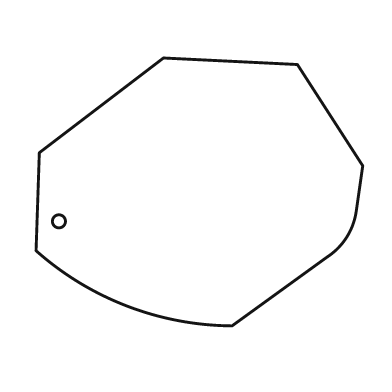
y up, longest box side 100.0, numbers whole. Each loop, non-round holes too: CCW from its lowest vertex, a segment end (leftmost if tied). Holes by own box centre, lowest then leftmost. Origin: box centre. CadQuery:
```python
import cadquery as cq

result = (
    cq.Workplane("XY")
    .moveTo(10.0, -41.0)
    .lineTo(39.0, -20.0)
    .threePointArc((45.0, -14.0), (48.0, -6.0))
    .lineTo(50.0, 8.0)
    .lineTo(30.0, 39.0)
    .lineTo(-11.0, 41.0)
    .lineTo(-49.0, 12.0)
    .lineTo(-50.0, -18.0)
    .threePointArc((-22.0, -35.0), (10.0, -41.0))
    .close()
    .moveTo(-43.0, -9.0)
    .circle(2.0)
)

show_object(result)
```